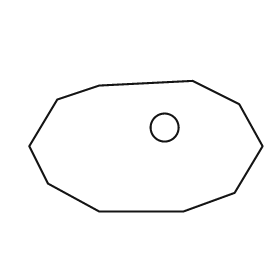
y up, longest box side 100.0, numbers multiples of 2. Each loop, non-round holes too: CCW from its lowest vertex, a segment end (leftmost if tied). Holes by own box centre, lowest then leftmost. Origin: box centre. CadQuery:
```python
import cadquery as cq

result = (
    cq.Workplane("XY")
    .moveTo(-20.0, -28.0)
    .lineTo(16.0, -28.0)
    .lineTo(38.0, -20.0)
    .lineTo(50.0, 0.0)
    .lineTo(40.0, 18.0)
    .lineTo(20.0, 28.0)
    .lineTo(-20.0, 26.0)
    .lineTo(-38.0, 20.0)
    .lineTo(-50.0, 0.0)
    .lineTo(-42.0, -16.0)
    .close()
    .moveTo(8.0, 8.0)
    .circle(6.0)
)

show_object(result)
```